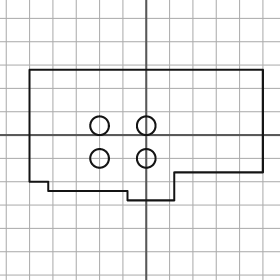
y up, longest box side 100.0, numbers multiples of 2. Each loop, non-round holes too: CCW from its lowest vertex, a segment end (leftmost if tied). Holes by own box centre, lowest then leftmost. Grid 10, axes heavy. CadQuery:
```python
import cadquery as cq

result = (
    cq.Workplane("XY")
    .moveTo(-8.0, -28.0)
    .lineTo(12.0, -28.0)
    .lineTo(12.0, -16.0)
    .lineTo(50.0, -16.0)
    .lineTo(50.0, 28.0)
    .lineTo(-50.0, 28.0)
    .lineTo(-50.0, -20.0)
    .lineTo(-42.0, -20.0)
    .lineTo(-42.0, -24.0)
    .lineTo(-8.0, -24.0)
    .close()
    .moveTo(-20.0, -10.0)
    .circle(4.0)
    .moveTo(0.0, -10.0)
    .circle(4.0)
    .moveTo(-20.0, 4.0)
    .circle(4.0)
    .moveTo(0.0, 4.0)
    .circle(4.0)
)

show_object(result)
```